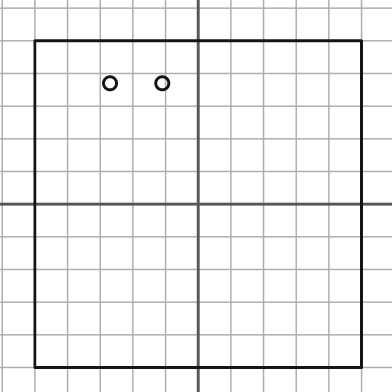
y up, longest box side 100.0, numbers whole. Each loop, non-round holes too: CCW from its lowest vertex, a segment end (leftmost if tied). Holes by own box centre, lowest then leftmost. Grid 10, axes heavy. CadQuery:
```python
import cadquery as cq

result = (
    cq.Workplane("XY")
    .moveTo(-50.0, -50.0)
    .lineTo(50.0, -50.0)
    .lineTo(50.0, 50.0)
    .lineTo(-50.0, 50.0)
    .close()
    .moveTo(-27.0, 37.0)
    .circle(2.0)
    .moveTo(-11.0, 37.0)
    .circle(2.0)
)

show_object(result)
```